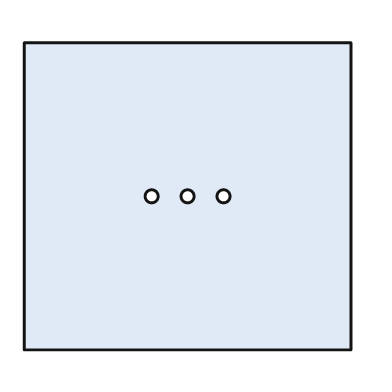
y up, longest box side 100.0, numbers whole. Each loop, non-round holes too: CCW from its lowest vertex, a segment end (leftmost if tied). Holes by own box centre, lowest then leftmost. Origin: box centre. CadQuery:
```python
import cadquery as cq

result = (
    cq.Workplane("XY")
    .moveTo(-50.0, -47.0)
    .lineTo(50.0, -47.0)
    .lineTo(50.0, 47.0)
    .lineTo(-50.0, 47.0)
    .close()
    .moveTo(-11.0, 0.0)
    .circle(2.0)
    .moveTo(0.0, 0.0)
    .circle(2.0)
    .moveTo(11.0, 0.0)
    .circle(2.0)
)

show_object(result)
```